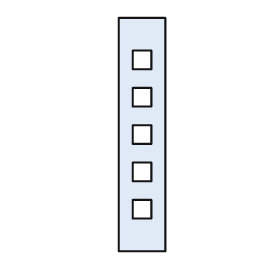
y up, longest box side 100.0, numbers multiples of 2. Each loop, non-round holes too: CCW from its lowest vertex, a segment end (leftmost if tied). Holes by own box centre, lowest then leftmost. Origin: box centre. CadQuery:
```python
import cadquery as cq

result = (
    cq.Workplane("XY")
    .moveTo(-10.0, -50.0)
    .lineTo(10.0, -50.0)
    .lineTo(10.0, 50.0)
    .lineTo(-10.0, 50.0)
    .close()
    .moveTo(-4.0, -36.0)
    .lineTo(4.0, -36.0)
    .lineTo(4.0, -28.0)
    .lineTo(-4.0, -28.0)
    .close()
    .moveTo(-4.0, -20.0)
    .lineTo(4.0, -20.0)
    .lineTo(4.0, -12.0)
    .lineTo(-4.0, -12.0)
    .close()
    .moveTo(-4.0, -4.0)
    .lineTo(4.0, -4.0)
    .lineTo(4.0, 4.0)
    .lineTo(-4.0, 4.0)
    .close()
    .moveTo(-4.0, 12.0)
    .lineTo(4.0, 12.0)
    .lineTo(4.0, 20.0)
    .lineTo(-4.0, 20.0)
    .close()
    .moveTo(-4.0, 28.0)
    .lineTo(4.0, 28.0)
    .lineTo(4.0, 36.0)
    .lineTo(-4.0, 36.0)
    .close()
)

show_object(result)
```